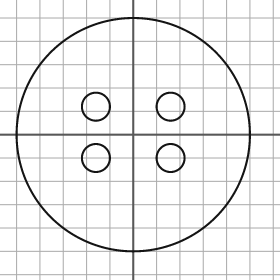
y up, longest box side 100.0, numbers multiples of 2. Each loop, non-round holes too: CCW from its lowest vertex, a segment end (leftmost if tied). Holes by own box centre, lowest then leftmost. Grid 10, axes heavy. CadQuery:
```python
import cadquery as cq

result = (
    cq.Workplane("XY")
    .moveTo(0.0, 0.0)
    .circle(50.0)
    .moveTo(-16.0, -10.0)
    .circle(6.0)
    .moveTo(16.0, -10.0)
    .circle(6.0)
    .moveTo(-16.0, 12.0)
    .circle(6.0)
    .moveTo(16.0, 12.0)
    .circle(6.0)
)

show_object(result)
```